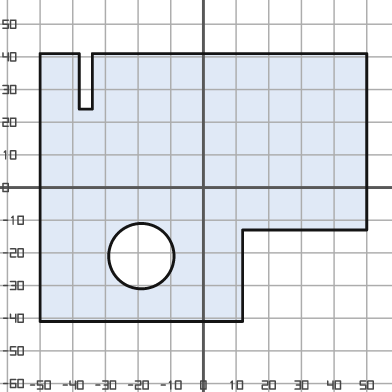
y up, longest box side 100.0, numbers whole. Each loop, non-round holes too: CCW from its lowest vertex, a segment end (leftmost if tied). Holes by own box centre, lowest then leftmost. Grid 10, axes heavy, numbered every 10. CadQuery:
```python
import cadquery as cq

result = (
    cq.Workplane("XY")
    .moveTo(-50.0, -41.0)
    .lineTo(12.0, -41.0)
    .lineTo(12.0, -13.0)
    .lineTo(50.0, -13.0)
    .lineTo(50.0, 41.0)
    .lineTo(-34.0, 41.0)
    .lineTo(-34.0, 24.0)
    .lineTo(-38.0, 24.0)
    .lineTo(-38.0, 41.0)
    .lineTo(-50.0, 41.0)
    .close()
    .moveTo(-19.0, -21.0)
    .circle(10.0)
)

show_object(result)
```